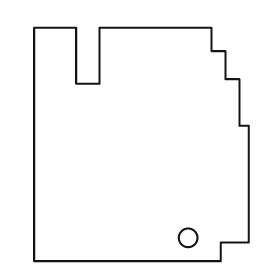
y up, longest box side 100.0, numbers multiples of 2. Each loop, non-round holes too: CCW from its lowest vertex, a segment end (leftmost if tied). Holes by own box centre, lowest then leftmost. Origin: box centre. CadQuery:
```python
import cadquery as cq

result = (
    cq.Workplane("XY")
    .moveTo(-46.0, -50.0)
    .lineTo(34.0, -50.0)
    .lineTo(34.0, -42.0)
    .lineTo(46.0, -42.0)
    .lineTo(46.0, 8.0)
    .lineTo(42.0, 8.0)
    .lineTo(42.0, 28.0)
    .lineTo(36.0, 28.0)
    .lineTo(36.0, 40.0)
    .lineTo(30.0, 40.0)
    .lineTo(30.0, 50.0)
    .lineTo(-18.0, 50.0)
    .lineTo(-18.0, 26.0)
    .lineTo(-28.0, 26.0)
    .lineTo(-28.0, 50.0)
    .lineTo(-46.0, 50.0)
    .close()
    .moveTo(20.0, -40.0)
    .circle(4.0)
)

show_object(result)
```